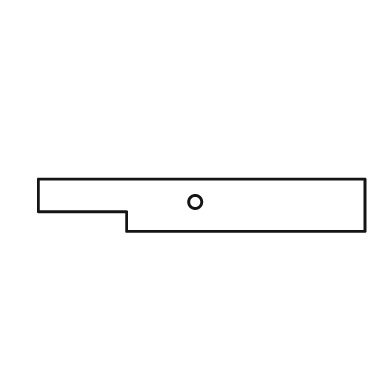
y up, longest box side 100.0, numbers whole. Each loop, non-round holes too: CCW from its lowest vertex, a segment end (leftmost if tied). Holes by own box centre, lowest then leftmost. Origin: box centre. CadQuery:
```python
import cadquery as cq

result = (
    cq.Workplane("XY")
    .moveTo(-23.0, -8.0)
    .lineTo(50.0, -8.0)
    .lineTo(50.0, 8.0)
    .lineTo(-50.0, 8.0)
    .lineTo(-50.0, -2.0)
    .lineTo(-23.0, -2.0)
    .close()
    .moveTo(-2.0, 1.0)
    .circle(2.0)
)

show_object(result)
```